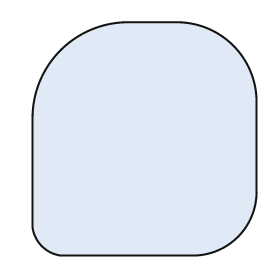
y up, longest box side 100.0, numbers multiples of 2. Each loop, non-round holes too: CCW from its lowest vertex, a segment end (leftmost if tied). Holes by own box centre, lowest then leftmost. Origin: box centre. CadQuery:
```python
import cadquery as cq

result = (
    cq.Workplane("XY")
    .moveTo(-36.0, -50.0)
    .lineTo(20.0, -50.0)
    .threePointArc((40.0, -42.0), (48.0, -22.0))
    .lineTo(48.0, 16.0)
    .threePointArc((38.0, 40.0), (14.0, 50.0))
    .lineTo(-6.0, 50.0)
    .threePointArc((-36.0, 38.0), (-48.0, 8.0))
    .lineTo(-48.0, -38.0)
    .threePointArc((-44.0, -46.0), (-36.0, -50.0))
    .close()
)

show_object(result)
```